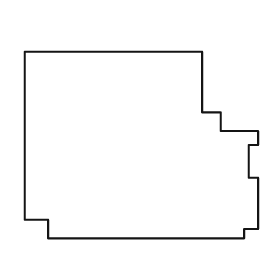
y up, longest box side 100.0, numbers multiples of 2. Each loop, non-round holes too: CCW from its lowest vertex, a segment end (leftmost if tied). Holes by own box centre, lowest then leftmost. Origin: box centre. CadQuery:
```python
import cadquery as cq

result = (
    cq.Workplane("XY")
    .moveTo(-40.0, -40.0)
    .lineTo(44.0, -40.0)
    .lineTo(44.0, -36.0)
    .lineTo(50.0, -36.0)
    .lineTo(50.0, -14.0)
    .lineTo(46.0, -14.0)
    .lineTo(46.0, 0.0)
    .lineTo(50.0, 0.0)
    .lineTo(50.0, 6.0)
    .lineTo(34.0, 6.0)
    .lineTo(34.0, 14.0)
    .lineTo(26.0, 14.0)
    .lineTo(26.0, 40.0)
    .lineTo(-50.0, 40.0)
    .lineTo(-50.0, -32.0)
    .lineTo(-40.0, -32.0)
    .close()
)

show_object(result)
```